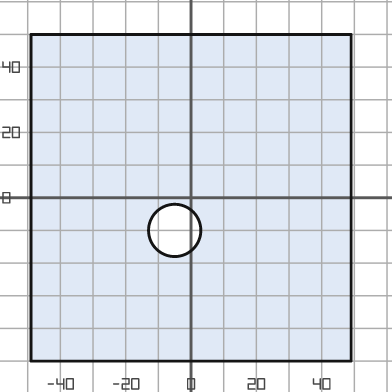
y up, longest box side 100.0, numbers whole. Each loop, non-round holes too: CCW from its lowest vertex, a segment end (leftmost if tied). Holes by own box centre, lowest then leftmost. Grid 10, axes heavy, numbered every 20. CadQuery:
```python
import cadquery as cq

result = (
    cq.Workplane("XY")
    .moveTo(-49.0, -50.0)
    .lineTo(49.0, -50.0)
    .lineTo(49.0, 50.0)
    .lineTo(-49.0, 50.0)
    .close()
    .moveTo(-5.0, -10.0)
    .circle(8.0)
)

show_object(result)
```